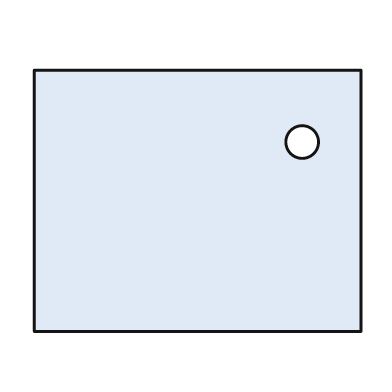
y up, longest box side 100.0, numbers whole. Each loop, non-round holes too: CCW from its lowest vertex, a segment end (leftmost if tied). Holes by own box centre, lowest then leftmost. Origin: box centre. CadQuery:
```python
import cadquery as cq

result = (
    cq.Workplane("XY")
    .moveTo(-50.0, -40.0)
    .lineTo(50.0, -40.0)
    .lineTo(50.0, 40.0)
    .lineTo(-50.0, 40.0)
    .close()
    .moveTo(32.0, 18.0)
    .circle(5.0)
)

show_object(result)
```